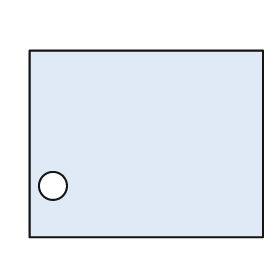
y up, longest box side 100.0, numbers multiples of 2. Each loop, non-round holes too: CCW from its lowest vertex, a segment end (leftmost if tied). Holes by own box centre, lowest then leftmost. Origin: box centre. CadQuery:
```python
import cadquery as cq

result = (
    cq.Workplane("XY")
    .moveTo(-50.0, -40.0)
    .lineTo(50.0, -40.0)
    .lineTo(50.0, 40.0)
    .lineTo(-50.0, 40.0)
    .close()
    .moveTo(-40.0, -18.0)
    .circle(6.0)
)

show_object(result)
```